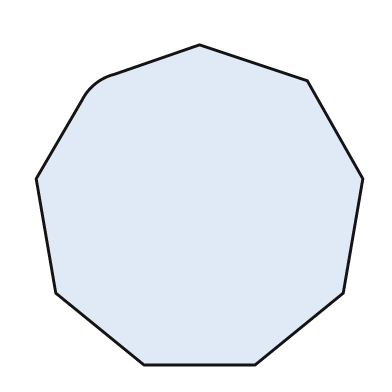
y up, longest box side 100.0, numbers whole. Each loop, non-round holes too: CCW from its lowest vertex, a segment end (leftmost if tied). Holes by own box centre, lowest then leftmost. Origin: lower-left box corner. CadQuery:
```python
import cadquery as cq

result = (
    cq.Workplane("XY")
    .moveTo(33.0, 0.0)
    .lineTo(67.0, 0.0)
    .lineTo(94.0, 22.0)
    .lineTo(100.0, 57.0)
    .lineTo(83.0, 87.0)
    .lineTo(50.0, 98.0)
    .lineTo(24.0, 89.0)
    .threePointArc((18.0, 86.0), (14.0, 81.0))
    .lineTo(0.0, 57.0)
    .lineTo(6.0, 22.0)
    .close()
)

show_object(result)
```